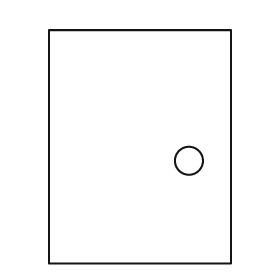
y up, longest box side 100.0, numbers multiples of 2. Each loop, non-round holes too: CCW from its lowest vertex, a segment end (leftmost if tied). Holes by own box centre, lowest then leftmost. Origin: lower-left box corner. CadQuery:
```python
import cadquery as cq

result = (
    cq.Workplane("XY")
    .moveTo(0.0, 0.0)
    .lineTo(78.0, 0.0)
    .lineTo(78.0, 100.0)
    .lineTo(0.0, 100.0)
    .close()
    .moveTo(60.0, 44.0)
    .circle(6.0)
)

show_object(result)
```